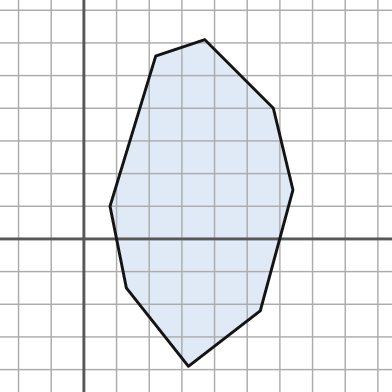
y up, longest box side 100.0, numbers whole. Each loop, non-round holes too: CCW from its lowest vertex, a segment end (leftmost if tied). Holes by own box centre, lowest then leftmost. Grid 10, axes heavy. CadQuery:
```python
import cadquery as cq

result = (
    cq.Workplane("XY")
    .moveTo(32.0, -39.0)
    .lineTo(54.0, -22.0)
    .lineTo(64.0, 15.0)
    .lineTo(58.0, 40.0)
    .lineTo(37.0, 61.0)
    .lineTo(22.0, 56.0)
    .lineTo(8.0, 10.0)
    .lineTo(13.0, -15.0)
    .close()
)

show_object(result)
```